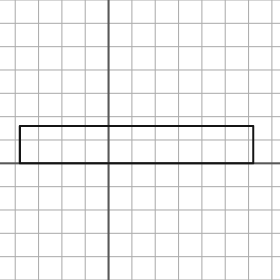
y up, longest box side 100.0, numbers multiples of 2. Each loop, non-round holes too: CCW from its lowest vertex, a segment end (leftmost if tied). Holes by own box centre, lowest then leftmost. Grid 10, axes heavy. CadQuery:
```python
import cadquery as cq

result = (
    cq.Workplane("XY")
    .moveTo(-38.0, 0.0)
    .lineTo(62.0, 0.0)
    .lineTo(62.0, 16.0)
    .lineTo(-38.0, 16.0)
    .close()
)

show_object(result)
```